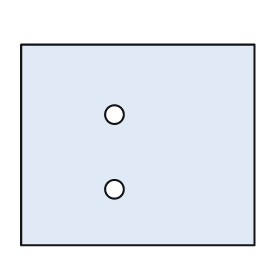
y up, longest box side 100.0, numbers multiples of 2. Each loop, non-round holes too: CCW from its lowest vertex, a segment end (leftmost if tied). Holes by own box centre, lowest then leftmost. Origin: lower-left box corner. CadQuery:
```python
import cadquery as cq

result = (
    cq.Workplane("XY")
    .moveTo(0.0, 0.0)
    .lineTo(100.0, 0.0)
    .lineTo(100.0, 86.0)
    .lineTo(0.0, 86.0)
    .close()
    .moveTo(40.0, 24.0)
    .circle(4.0)
    .moveTo(40.0, 56.0)
    .circle(4.0)
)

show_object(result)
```